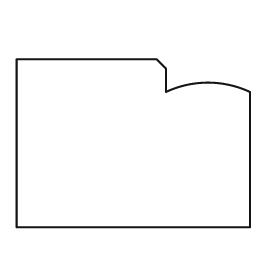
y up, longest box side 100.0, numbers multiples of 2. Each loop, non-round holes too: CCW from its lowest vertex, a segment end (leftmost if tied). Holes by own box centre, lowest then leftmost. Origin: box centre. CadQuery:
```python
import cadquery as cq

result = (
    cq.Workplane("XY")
    .moveTo(-50.0, -36.0)
    .lineTo(50.0, -36.0)
    .lineTo(50.0, 22.0)
    .threePointArc((32.0, 26.0), (14.0, 22.0))
    .lineTo(14.0, 32.0)
    .lineTo(10.0, 36.0)
    .lineTo(-50.0, 36.0)
    .close()
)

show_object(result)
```